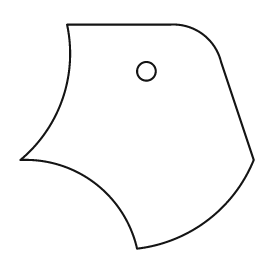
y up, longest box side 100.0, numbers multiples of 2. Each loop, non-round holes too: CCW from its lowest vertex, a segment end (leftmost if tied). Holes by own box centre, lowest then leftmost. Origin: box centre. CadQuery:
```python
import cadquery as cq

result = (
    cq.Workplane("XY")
    .moveTo(0.0, -48.0)
    .threePointArc((30.0, -36.0), (50.0, -10.0))
    .lineTo(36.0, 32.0)
    .threePointArc((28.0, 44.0), (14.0, 48.0))
    .lineTo(-30.0, 48.0)
    .threePointArc((-32.0, 16.0), (-50.0, -10.0))
    .threePointArc((-18.0, -20.0), (0.0, -48.0))
    .close()
    .moveTo(4.0, 28.0)
    .circle(4.0)
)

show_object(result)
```